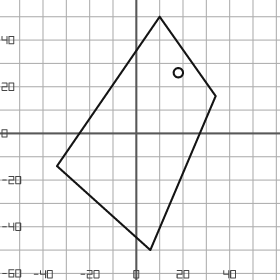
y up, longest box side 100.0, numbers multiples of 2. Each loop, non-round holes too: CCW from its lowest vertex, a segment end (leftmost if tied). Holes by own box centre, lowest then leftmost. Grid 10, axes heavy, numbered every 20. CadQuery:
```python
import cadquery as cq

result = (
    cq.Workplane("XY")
    .moveTo(6.0, -50.0)
    .lineTo(34.0, 16.0)
    .lineTo(10.0, 50.0)
    .lineTo(-34.0, -14.0)
    .close()
    .moveTo(18.0, 26.0)
    .circle(2.0)
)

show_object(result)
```